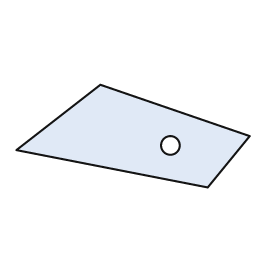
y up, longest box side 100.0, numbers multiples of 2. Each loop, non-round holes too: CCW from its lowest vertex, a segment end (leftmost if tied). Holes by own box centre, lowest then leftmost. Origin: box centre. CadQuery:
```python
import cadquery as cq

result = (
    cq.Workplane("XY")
    .moveTo(32.0, -22.0)
    .lineTo(50.0, 0.0)
    .lineTo(-14.0, 22.0)
    .lineTo(-50.0, -6.0)
    .close()
    .moveTo(16.0, -4.0)
    .circle(4.0)
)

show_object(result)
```